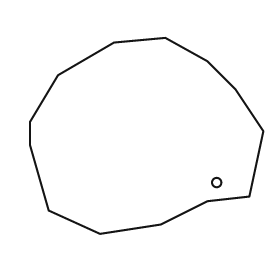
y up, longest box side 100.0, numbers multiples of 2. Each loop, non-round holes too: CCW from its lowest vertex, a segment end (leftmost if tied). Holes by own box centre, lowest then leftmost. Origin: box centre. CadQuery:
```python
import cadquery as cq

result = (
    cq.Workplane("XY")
    .moveTo(-20.0, -42.0)
    .lineTo(6.0, -38.0)
    .lineTo(26.0, -28.0)
    .lineTo(44.0, -26.0)
    .lineTo(50.0, 2.0)
    .lineTo(38.0, 20.0)
    .lineTo(26.0, 32.0)
    .lineTo(8.0, 42.0)
    .lineTo(-14.0, 40.0)
    .lineTo(-38.0, 26.0)
    .lineTo(-50.0, 6.0)
    .lineTo(-50.0, -4.0)
    .lineTo(-42.0, -32.0)
    .close()
    .moveTo(30.0, -20.0)
    .circle(2.0)
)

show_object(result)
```